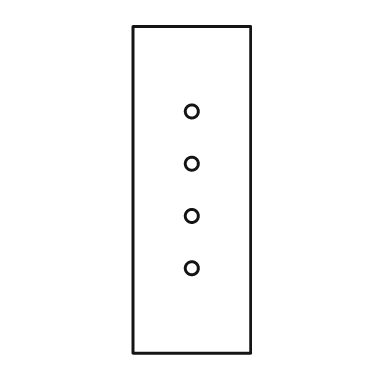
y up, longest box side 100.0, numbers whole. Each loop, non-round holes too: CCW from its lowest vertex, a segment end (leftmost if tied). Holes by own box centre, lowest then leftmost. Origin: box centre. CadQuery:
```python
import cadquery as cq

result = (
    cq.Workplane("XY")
    .moveTo(-18.0, -50.0)
    .lineTo(18.0, -50.0)
    .lineTo(18.0, 50.0)
    .lineTo(-18.0, 50.0)
    .close()
    .moveTo(0.0, -24.0)
    .circle(2.0)
    .moveTo(0.0, -8.0)
    .circle(2.0)
    .moveTo(0.0, 8.0)
    .circle(2.0)
    .moveTo(0.0, 24.0)
    .circle(2.0)
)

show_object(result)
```